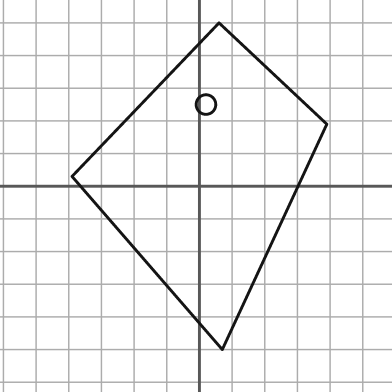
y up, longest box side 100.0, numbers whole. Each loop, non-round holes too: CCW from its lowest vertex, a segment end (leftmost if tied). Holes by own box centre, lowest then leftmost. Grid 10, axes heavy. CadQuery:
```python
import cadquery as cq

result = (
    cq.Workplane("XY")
    .moveTo(7.0, -50.0)
    .lineTo(39.0, 19.0)
    .lineTo(6.0, 50.0)
    .lineTo(-39.0, 3.0)
    .close()
    .moveTo(2.0, 25.0)
    .circle(3.0)
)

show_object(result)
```